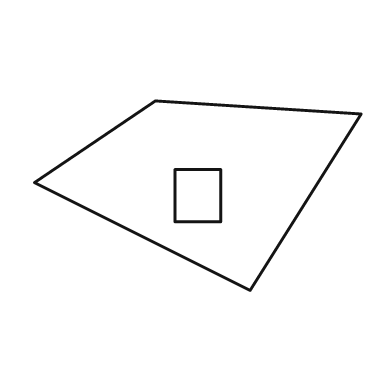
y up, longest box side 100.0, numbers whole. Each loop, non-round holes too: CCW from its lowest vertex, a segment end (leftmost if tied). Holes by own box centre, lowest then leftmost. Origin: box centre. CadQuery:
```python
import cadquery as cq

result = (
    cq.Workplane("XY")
    .moveTo(16.0, -29.0)
    .lineTo(50.0, 25.0)
    .lineTo(-13.0, 29.0)
    .lineTo(-50.0, 4.0)
    .close()
    .moveTo(-7.0, -8.0)
    .lineTo(7.0, -8.0)
    .lineTo(7.0, 8.0)
    .lineTo(-7.0, 8.0)
    .close()
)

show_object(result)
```